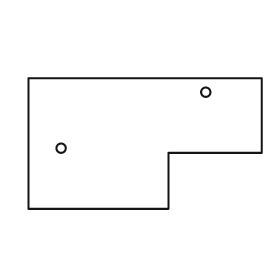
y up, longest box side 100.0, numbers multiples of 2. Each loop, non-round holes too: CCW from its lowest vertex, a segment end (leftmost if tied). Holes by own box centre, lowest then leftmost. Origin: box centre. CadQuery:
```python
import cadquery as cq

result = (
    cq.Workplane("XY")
    .moveTo(-50.0, -28.0)
    .lineTo(10.0, -28.0)
    .lineTo(10.0, -4.0)
    .lineTo(50.0, -4.0)
    .lineTo(50.0, 28.0)
    .lineTo(-50.0, 28.0)
    .close()
    .moveTo(-36.0, -2.0)
    .circle(2.0)
    .moveTo(26.0, 22.0)
    .circle(2.0)
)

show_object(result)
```